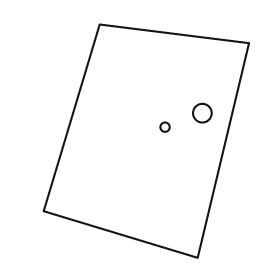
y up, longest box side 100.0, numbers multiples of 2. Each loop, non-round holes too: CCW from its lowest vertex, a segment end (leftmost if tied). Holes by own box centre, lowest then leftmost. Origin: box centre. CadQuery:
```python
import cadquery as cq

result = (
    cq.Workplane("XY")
    .moveTo(22.0, -50.0)
    .lineTo(44.0, 42.0)
    .lineTo(-20.0, 50.0)
    .lineTo(-44.0, -30.0)
    .close()
    .moveTo(8.0, 6.0)
    .circle(2.0)
    .moveTo(24.0, 12.0)
    .circle(4.0)
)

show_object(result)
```